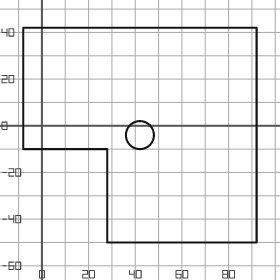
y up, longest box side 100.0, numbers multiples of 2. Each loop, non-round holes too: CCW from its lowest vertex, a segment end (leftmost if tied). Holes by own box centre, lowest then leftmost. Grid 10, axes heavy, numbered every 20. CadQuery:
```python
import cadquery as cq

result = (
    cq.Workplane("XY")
    .moveTo(28.0, -50.0)
    .lineTo(92.0, -50.0)
    .lineTo(92.0, 42.0)
    .lineTo(-8.0, 42.0)
    .lineTo(-8.0, -10.0)
    .lineTo(28.0, -10.0)
    .close()
    .moveTo(42.0, -4.0)
    .circle(6.0)
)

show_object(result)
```